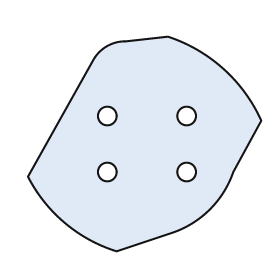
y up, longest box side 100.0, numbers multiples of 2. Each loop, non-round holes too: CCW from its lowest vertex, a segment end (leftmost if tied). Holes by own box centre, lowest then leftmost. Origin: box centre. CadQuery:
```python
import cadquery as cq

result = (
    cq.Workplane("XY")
    .moveTo(-12.0, -46.0)
    .lineTo(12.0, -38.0)
    .threePointArc((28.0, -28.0), (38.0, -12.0))
    .lineTo(50.0, 10.0)
    .threePointArc((34.0, 32.0), (10.0, 46.0))
    .lineTo(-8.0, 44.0)
    .threePointArc((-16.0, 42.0), (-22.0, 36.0))
    .lineTo(-50.0, -14.0)
    .threePointArc((-34.0, -34.0), (-12.0, -46.0))
    .close()
    .moveTo(-16.0, -12.0)
    .circle(4.0)
    .moveTo(18.0, -12.0)
    .circle(4.0)
    .moveTo(-16.0, 12.0)
    .circle(4.0)
    .moveTo(18.0, 12.0)
    .circle(4.0)
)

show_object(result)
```